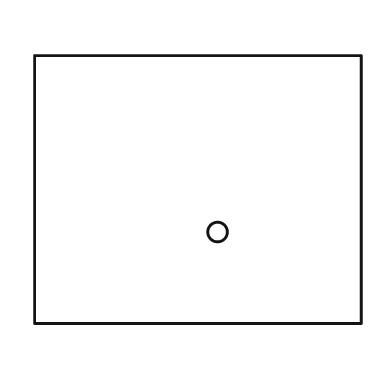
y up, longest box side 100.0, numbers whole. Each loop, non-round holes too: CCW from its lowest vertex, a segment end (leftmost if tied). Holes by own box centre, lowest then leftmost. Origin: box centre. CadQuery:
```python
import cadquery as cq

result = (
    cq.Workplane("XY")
    .moveTo(-50.0, -41.0)
    .lineTo(50.0, -41.0)
    .lineTo(50.0, 41.0)
    .lineTo(-50.0, 41.0)
    .close()
    .moveTo(6.0, -13.0)
    .circle(3.0)
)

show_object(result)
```